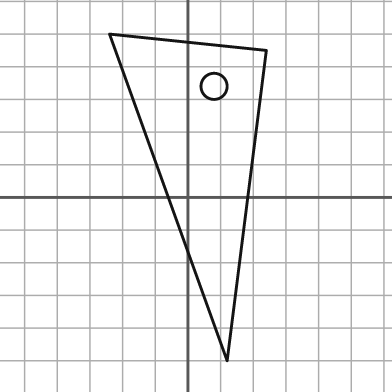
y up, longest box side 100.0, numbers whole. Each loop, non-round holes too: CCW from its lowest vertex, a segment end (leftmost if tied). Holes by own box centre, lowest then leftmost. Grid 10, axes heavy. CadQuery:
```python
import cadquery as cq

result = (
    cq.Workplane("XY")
    .moveTo(12.0, -50.0)
    .lineTo(24.0, 45.0)
    .lineTo(-24.0, 50.0)
    .close()
    .moveTo(8.0, 34.0)
    .circle(4.0)
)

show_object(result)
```